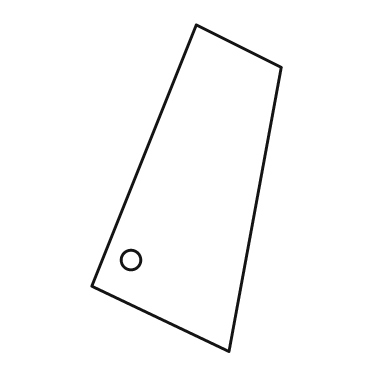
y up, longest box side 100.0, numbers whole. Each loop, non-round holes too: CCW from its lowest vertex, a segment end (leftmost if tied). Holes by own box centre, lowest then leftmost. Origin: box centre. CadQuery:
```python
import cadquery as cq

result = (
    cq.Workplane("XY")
    .moveTo(13.0, -50.0)
    .lineTo(29.0, 37.0)
    .lineTo(3.0, 50.0)
    .lineTo(-29.0, -30.0)
    .close()
    .moveTo(-17.0, -22.0)
    .circle(3.0)
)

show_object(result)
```